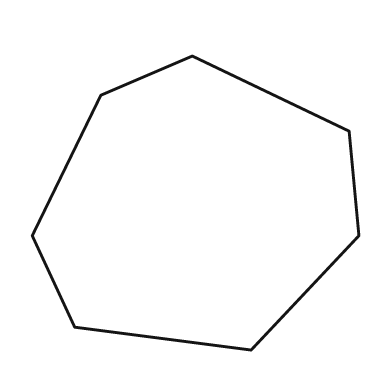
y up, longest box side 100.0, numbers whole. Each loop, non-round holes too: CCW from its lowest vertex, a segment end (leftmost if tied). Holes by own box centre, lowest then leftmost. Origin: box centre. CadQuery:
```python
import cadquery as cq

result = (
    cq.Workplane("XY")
    .moveTo(17.0, -45.0)
    .lineTo(50.0, -10.0)
    .lineTo(47.0, 22.0)
    .lineTo(-1.0, 45.0)
    .lineTo(-29.0, 33.0)
    .lineTo(-50.0, -10.0)
    .lineTo(-37.0, -38.0)
    .close()
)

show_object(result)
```